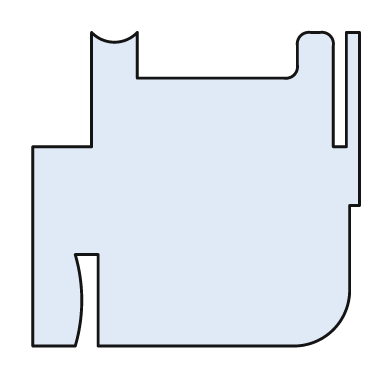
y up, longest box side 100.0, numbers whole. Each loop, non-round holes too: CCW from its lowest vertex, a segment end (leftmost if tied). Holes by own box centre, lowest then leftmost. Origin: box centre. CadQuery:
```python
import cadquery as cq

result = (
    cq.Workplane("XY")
    .moveTo(-50.0, -48.0)
    .lineTo(-37.0, -48.0)
    .threePointArc((-35.0, -34.0), (-37.0, -20.0))
    .lineTo(-30.0, -20.0)
    .lineTo(-30.0, -48.0)
    .lineTo(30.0, -48.0)
    .threePointArc((42.0, -43.0), (47.0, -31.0))
    .lineTo(47.0, -5.0)
    .lineTo(50.0, -5.0)
    .lineTo(50.0, 48.0)
    .lineTo(46.0, 48.0)
    .lineTo(46.0, 13.0)
    .lineTo(42.0, 13.0)
    .lineTo(42.0, 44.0)
    .threePointArc((41.0, 47.0), (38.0, 48.0))
    .lineTo(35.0, 48.0)
    .threePointArc((32.0, 47.0), (31.0, 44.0))
    .lineTo(31.0, 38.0)
    .threePointArc((30.0, 35.0), (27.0, 34.0))
    .lineTo(-18.0, 34.0)
    .lineTo(-18.0, 48.0)
    .threePointArc((-25.0, 45.0), (-32.0, 48.0))
    .lineTo(-32.0, 13.0)
    .lineTo(-50.0, 13.0)
    .close()
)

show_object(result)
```